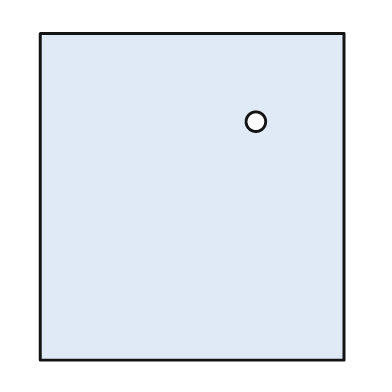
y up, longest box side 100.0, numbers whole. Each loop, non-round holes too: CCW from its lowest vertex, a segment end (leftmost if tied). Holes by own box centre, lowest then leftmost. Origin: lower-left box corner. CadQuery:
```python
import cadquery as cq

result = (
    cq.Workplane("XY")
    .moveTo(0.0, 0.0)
    .lineTo(93.0, 0.0)
    .lineTo(93.0, 100.0)
    .lineTo(0.0, 100.0)
    .close()
    .moveTo(66.0, 73.0)
    .circle(3.0)
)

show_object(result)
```